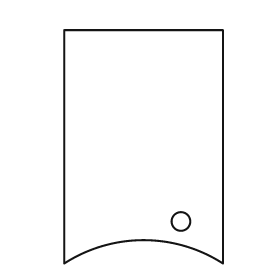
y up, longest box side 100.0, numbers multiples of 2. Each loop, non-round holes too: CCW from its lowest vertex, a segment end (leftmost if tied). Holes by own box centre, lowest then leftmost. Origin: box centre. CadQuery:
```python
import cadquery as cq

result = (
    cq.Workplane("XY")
    .moveTo(-34.0, -50.0)
    .threePointArc((0.0, -40.0), (34.0, -50.0))
    .lineTo(34.0, 50.0)
    .lineTo(-34.0, 50.0)
    .close()
    .moveTo(16.0, -32.0)
    .circle(4.0)
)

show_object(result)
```